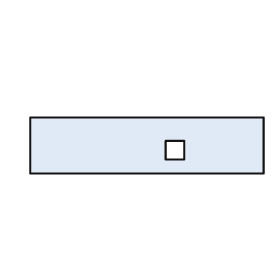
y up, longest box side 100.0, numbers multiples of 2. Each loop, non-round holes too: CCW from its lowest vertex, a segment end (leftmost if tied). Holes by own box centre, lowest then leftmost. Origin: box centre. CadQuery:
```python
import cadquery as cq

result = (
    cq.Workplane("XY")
    .moveTo(-50.0, -12.0)
    .lineTo(50.0, -12.0)
    .lineTo(50.0, 12.0)
    .lineTo(-50.0, 12.0)
    .close()
    .moveTo(8.0, -6.0)
    .lineTo(16.0, -6.0)
    .lineTo(16.0, 2.0)
    .lineTo(8.0, 2.0)
    .close()
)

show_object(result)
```